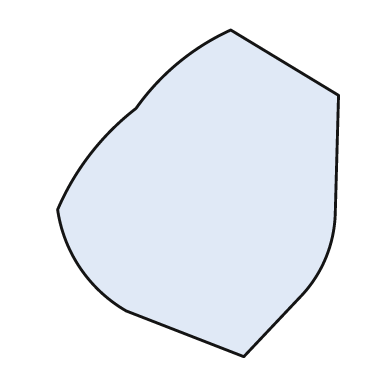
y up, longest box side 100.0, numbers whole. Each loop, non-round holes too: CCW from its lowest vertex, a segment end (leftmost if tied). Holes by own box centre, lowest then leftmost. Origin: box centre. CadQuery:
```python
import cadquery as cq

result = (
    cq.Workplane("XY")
    .moveTo(14.0, -50.0)
    .lineTo(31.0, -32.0)
    .threePointArc((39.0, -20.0), (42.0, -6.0))
    .lineTo(43.0, 30.0)
    .lineTo(10.0, 50.0)
    .threePointArc((-6.0, 40.0), (-19.0, 26.0))
    .threePointArc((-33.0, 12.0), (-43.0, -5.0))
    .threePointArc((-36.0, -23.0), (-22.0, -36.0))
    .close()
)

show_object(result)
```